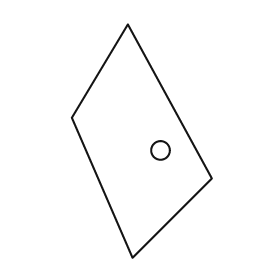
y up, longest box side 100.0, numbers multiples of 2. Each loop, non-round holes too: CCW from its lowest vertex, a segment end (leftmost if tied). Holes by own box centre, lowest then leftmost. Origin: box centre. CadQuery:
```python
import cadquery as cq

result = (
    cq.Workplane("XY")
    .moveTo(-4.0, -50.0)
    .lineTo(30.0, -16.0)
    .lineTo(-6.0, 50.0)
    .lineTo(-30.0, 10.0)
    .close()
    .moveTo(8.0, -4.0)
    .circle(4.0)
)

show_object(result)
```